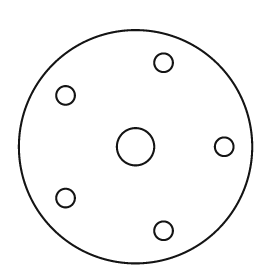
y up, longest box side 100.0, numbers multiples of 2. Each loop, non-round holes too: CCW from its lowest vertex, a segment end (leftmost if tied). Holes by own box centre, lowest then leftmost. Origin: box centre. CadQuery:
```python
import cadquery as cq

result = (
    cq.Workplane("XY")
    .moveTo(0.0, 0.0)
    .circle(50.0)
    .moveTo(12.0, -36.0)
    .circle(4.0)
    .moveTo(-30.0, -22.0)
    .circle(4.0)
    .moveTo(0.0, 0.0)
    .circle(8.0)
    .moveTo(38.0, 0.0)
    .circle(4.0)
    .moveTo(-30.0, 22.0)
    .circle(4.0)
    .moveTo(12.0, 36.0)
    .circle(4.0)
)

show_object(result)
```